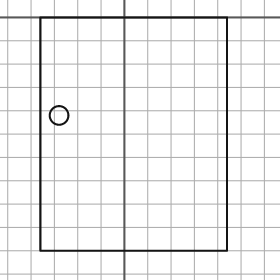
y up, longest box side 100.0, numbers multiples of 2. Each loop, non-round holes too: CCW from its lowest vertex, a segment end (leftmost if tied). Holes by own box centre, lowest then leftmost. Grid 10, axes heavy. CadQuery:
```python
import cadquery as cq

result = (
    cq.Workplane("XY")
    .moveTo(-36.0, -100.0)
    .lineTo(44.0, -100.0)
    .lineTo(44.0, 0.0)
    .lineTo(-36.0, 0.0)
    .close()
    .moveTo(-28.0, -42.0)
    .circle(4.0)
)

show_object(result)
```